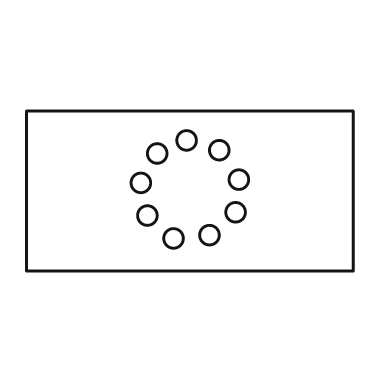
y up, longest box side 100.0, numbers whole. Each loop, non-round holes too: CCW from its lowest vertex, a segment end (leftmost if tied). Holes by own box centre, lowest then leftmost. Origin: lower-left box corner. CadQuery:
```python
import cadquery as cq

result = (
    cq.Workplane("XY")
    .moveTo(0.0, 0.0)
    .lineTo(100.0, 0.0)
    .lineTo(100.0, 49.0)
    .lineTo(0.0, 49.0)
    .close()
    .moveTo(45.0, 10.0)
    .circle(3.0)
    .moveTo(56.0, 11.0)
    .circle(3.0)
    .moveTo(37.0, 17.0)
    .circle(3.0)
    .moveTo(64.0, 18.0)
    .circle(3.0)
    .moveTo(35.0, 27.0)
    .circle(3.0)
    .moveTo(65.0, 28.0)
    .circle(3.0)
    .moveTo(40.0, 36.0)
    .circle(3.0)
    .moveTo(59.0, 37.0)
    .circle(3.0)
    .moveTo(49.0, 40.0)
    .circle(3.0)
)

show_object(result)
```